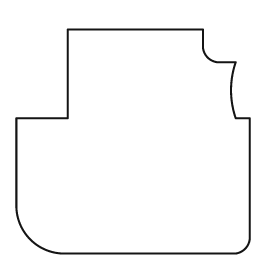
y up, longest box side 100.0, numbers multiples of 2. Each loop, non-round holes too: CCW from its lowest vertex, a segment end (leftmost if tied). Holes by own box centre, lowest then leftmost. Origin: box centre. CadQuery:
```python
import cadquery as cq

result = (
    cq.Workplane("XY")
    .moveTo(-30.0, -48.0)
    .lineTo(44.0, -48.0)
    .threePointArc((48.0, -46.0), (50.0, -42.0))
    .lineTo(50.0, 10.0)
    .lineTo(44.0, 10.0)
    .threePointArc((42.0, 22.0), (44.0, 34.0))
    .lineTo(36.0, 34.0)
    .threePointArc((32.0, 36.0), (30.0, 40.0))
    .lineTo(30.0, 48.0)
    .lineTo(-28.0, 48.0)
    .lineTo(-28.0, 10.0)
    .lineTo(-50.0, 10.0)
    .lineTo(-50.0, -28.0)
    .threePointArc((-44.0, -42.0), (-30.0, -48.0))
    .close()
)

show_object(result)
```